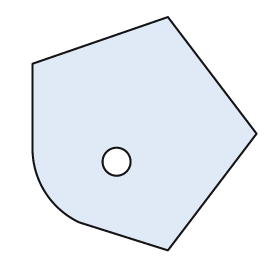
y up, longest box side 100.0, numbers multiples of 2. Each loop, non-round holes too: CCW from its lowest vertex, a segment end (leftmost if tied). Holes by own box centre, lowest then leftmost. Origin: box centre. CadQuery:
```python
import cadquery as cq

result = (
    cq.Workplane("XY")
    .moveTo(10.0, -50.0)
    .lineTo(48.0, 0.0)
    .lineTo(10.0, 50.0)
    .lineTo(-48.0, 30.0)
    .lineTo(-48.0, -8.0)
    .threePointArc((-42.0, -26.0), (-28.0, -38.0))
    .close()
    .moveTo(-12.0, -12.0)
    .circle(6.0)
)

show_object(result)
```